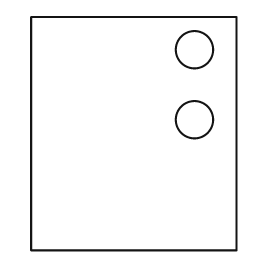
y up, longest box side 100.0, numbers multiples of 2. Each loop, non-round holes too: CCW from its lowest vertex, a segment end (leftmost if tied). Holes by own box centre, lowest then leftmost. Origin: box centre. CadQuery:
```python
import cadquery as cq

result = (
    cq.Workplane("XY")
    .moveTo(-44.0, -50.0)
    .lineTo(44.0, -50.0)
    .lineTo(44.0, 50.0)
    .lineTo(-44.0, 50.0)
    .close()
    .moveTo(26.0, 6.0)
    .circle(8.0)
    .moveTo(26.0, 36.0)
    .circle(8.0)
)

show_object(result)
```